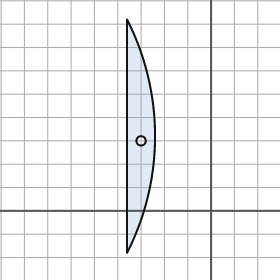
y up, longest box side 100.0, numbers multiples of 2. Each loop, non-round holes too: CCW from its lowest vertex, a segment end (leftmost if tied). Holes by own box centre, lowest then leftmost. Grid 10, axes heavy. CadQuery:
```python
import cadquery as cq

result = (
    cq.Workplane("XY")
    .moveTo(-36.0, -18.0)
    .threePointArc((-24.0, 32.0), (-36.0, 82.0))
    .close()
    .moveTo(-30.0, 30.0)
    .circle(2.0)
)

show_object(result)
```